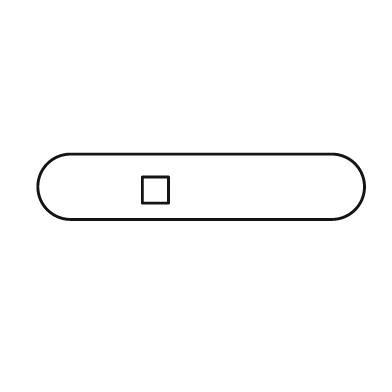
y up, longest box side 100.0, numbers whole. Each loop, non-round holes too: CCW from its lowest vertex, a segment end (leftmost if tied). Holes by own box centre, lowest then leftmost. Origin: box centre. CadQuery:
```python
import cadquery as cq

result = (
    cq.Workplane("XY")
    .moveTo(-40.0, -10.0)
    .lineTo(40.0, -10.0)
    .threePointArc((50.0, 0.0), (40.0, 10.0))
    .lineTo(-40.0, 10.0)
    .threePointArc((-50.0, 0.0), (-40.0, -10.0))
    .close()
    .moveTo(-18.0, -5.0)
    .lineTo(-10.0, -5.0)
    .lineTo(-10.0, 3.0)
    .lineTo(-18.0, 3.0)
    .close()
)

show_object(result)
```